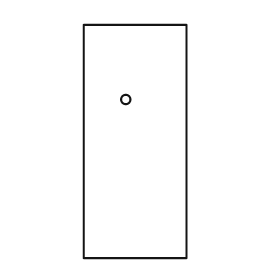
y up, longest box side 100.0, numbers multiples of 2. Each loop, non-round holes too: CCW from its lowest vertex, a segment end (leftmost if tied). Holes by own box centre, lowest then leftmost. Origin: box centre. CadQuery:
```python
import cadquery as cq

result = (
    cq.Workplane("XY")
    .moveTo(-22.0, -50.0)
    .lineTo(22.0, -50.0)
    .lineTo(22.0, 50.0)
    .lineTo(-22.0, 50.0)
    .close()
    .moveTo(-4.0, 18.0)
    .circle(2.0)
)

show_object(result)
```